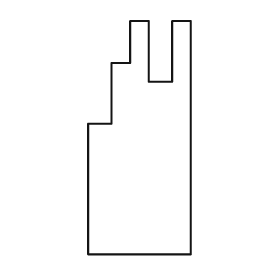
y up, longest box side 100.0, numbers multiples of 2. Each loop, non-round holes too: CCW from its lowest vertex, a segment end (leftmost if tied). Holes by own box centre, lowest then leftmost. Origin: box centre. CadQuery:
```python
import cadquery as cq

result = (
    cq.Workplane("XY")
    .moveTo(-22.0, -50.0)
    .lineTo(22.0, -50.0)
    .lineTo(22.0, 50.0)
    .lineTo(14.0, 50.0)
    .lineTo(14.0, 24.0)
    .lineTo(4.0, 24.0)
    .lineTo(4.0, 50.0)
    .lineTo(-4.0, 50.0)
    .lineTo(-4.0, 32.0)
    .lineTo(-12.0, 32.0)
    .lineTo(-12.0, 6.0)
    .lineTo(-22.0, 6.0)
    .close()
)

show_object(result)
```